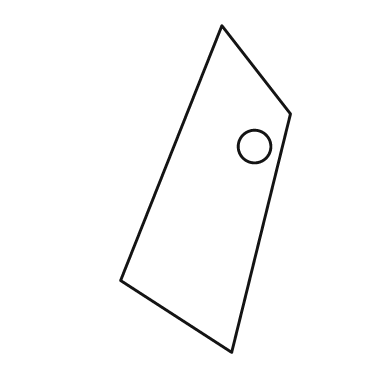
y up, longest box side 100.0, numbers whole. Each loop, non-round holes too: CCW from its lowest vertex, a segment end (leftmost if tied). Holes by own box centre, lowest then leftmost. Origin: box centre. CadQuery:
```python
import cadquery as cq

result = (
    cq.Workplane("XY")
    .moveTo(8.0, -50.0)
    .lineTo(26.0, 23.0)
    .lineTo(5.0, 50.0)
    .lineTo(-26.0, -28.0)
    .close()
    .moveTo(15.0, 13.0)
    .circle(5.0)
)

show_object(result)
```